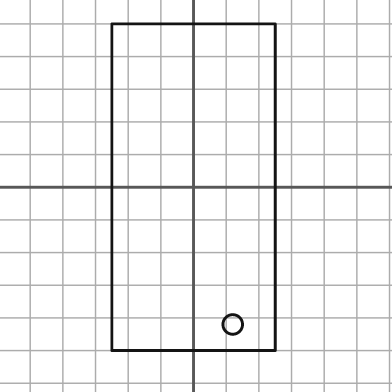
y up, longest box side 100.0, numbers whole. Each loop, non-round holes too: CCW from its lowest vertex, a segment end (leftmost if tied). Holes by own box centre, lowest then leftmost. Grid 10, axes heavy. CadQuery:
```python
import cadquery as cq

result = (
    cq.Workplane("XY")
    .moveTo(-25.0, -50.0)
    .lineTo(25.0, -50.0)
    .lineTo(25.0, 50.0)
    .lineTo(-25.0, 50.0)
    .close()
    .moveTo(12.0, -42.0)
    .circle(3.0)
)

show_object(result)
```